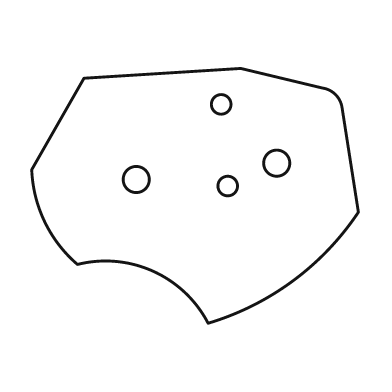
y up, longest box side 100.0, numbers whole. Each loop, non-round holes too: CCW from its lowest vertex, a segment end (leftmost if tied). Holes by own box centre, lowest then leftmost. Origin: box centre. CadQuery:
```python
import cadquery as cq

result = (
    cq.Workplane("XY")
    .moveTo(4.0, -39.0)
    .threePointArc((30.0, -26.0), (50.0, -5.0))
    .lineTo(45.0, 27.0)
    .threePointArc((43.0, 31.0), (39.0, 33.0))
    .lineTo(14.0, 39.0)
    .lineTo(-34.0, 36.0)
    .lineTo(-50.0, 8.0)
    .threePointArc((-46.0, -8.0), (-36.0, -21.0))
    .threePointArc((-13.0, -23.0), (4.0, -39.0))
    .close()
    .moveTo(10.0, 3.0)
    .circle(3.0)
    .moveTo(-18.0, 5.0)
    .circle(4.0)
    .moveTo(25.0, 10.0)
    .circle(4.0)
    .moveTo(8.0, 28.0)
    .circle(3.0)
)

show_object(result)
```